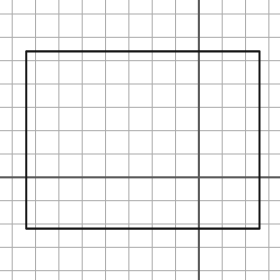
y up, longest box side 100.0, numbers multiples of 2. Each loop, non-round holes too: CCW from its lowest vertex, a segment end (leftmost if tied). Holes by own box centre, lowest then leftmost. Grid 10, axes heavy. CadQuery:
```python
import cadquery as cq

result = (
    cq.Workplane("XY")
    .moveTo(-74.0, -22.0)
    .lineTo(26.0, -22.0)
    .lineTo(26.0, 54.0)
    .lineTo(-74.0, 54.0)
    .close()
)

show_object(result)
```